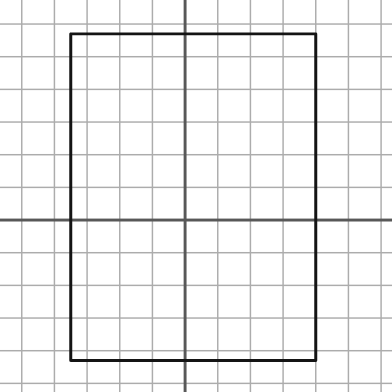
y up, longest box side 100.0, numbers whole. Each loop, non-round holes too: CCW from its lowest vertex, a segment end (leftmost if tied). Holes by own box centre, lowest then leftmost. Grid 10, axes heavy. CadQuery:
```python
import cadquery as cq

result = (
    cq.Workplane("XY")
    .moveTo(-35.0, -43.0)
    .lineTo(40.0, -43.0)
    .lineTo(40.0, 57.0)
    .lineTo(-35.0, 57.0)
    .close()
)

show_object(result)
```